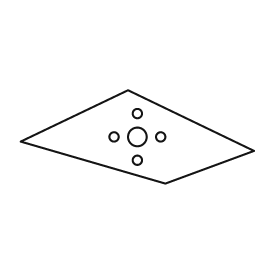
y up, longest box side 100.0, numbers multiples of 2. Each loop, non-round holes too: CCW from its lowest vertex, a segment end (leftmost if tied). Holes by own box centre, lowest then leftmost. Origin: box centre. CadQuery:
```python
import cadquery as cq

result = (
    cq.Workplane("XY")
    .moveTo(12.0, -20.0)
    .lineTo(50.0, -6.0)
    .lineTo(-4.0, 20.0)
    .lineTo(-50.0, -2.0)
    .close()
    .moveTo(0.0, -10.0)
    .circle(2.0)
    .moveTo(-10.0, 0.0)
    .circle(2.0)
    .moveTo(0.0, 0.0)
    .circle(4.0)
    .moveTo(10.0, 0.0)
    .circle(2.0)
    .moveTo(0.0, 10.0)
    .circle(2.0)
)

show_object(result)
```